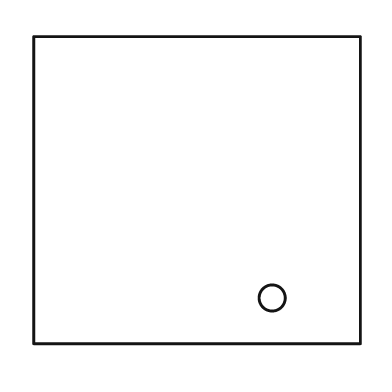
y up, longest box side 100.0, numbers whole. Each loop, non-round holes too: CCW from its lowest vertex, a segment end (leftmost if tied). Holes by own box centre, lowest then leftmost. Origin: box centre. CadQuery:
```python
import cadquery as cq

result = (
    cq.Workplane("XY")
    .moveTo(-50.0, -47.0)
    .lineTo(50.0, -47.0)
    .lineTo(50.0, 47.0)
    .lineTo(-50.0, 47.0)
    .close()
    .moveTo(23.0, -33.0)
    .circle(4.0)
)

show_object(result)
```